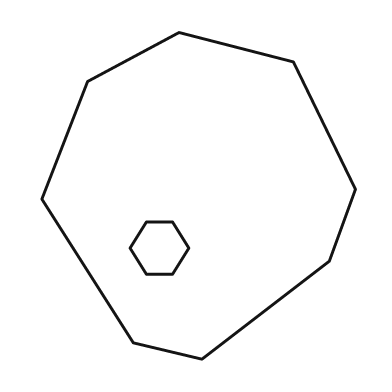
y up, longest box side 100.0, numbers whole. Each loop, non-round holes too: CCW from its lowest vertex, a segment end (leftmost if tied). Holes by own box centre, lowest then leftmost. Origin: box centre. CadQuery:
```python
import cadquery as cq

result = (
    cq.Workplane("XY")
    .moveTo(1.0, -50.0)
    .lineTo(40.0, -20.0)
    .lineTo(48.0, 2.0)
    .lineTo(29.0, 41.0)
    .lineTo(-6.0, 50.0)
    .lineTo(-34.0, 35.0)
    .lineTo(-48.0, -1.0)
    .lineTo(-20.0, -45.0)
    .close()
    .moveTo(-16.0, -24.0)
    .lineTo(-8.0, -24.0)
    .lineTo(-3.0, -16.0)
    .lineTo(-8.0, -8.0)
    .lineTo(-16.0, -8.0)
    .lineTo(-21.0, -16.0)
    .close()
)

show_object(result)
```